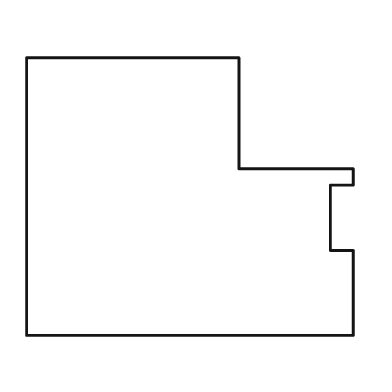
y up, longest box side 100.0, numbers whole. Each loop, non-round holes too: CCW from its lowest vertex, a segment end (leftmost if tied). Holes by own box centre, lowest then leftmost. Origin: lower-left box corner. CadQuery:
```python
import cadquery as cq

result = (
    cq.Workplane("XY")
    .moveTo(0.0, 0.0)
    .lineTo(100.0, 0.0)
    .lineTo(100.0, 26.0)
    .lineTo(93.0, 26.0)
    .lineTo(93.0, 46.0)
    .lineTo(100.0, 46.0)
    .lineTo(100.0, 51.0)
    .lineTo(65.0, 51.0)
    .lineTo(65.0, 85.0)
    .lineTo(0.0, 85.0)
    .close()
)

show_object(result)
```